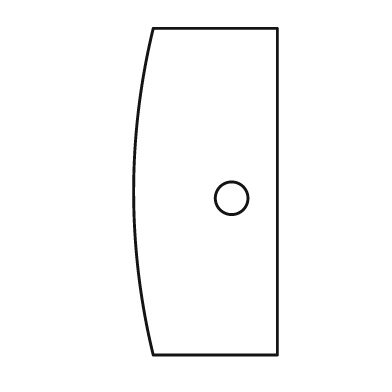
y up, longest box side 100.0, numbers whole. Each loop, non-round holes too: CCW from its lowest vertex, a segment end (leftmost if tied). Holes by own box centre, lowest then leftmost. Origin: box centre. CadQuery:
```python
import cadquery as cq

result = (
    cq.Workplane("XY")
    .moveTo(-16.0, -50.0)
    .lineTo(22.0, -50.0)
    .lineTo(22.0, 50.0)
    .lineTo(-16.0, 50.0)
    .threePointArc((-22.0, 0.0), (-16.0, -50.0))
    .close()
    .moveTo(8.0, -2.0)
    .circle(5.0)
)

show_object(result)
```